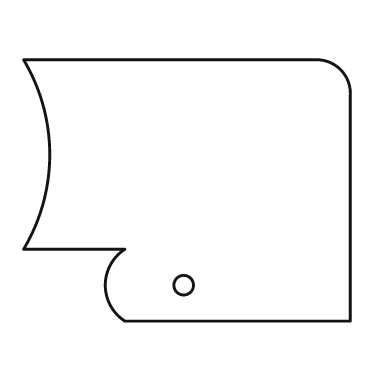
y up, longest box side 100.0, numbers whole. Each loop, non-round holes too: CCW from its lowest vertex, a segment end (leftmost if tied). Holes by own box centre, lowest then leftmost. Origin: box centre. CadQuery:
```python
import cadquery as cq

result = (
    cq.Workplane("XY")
    .moveTo(-19.0, -40.0)
    .lineTo(50.0, -40.0)
    .lineTo(50.0, 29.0)
    .threePointArc((47.0, 37.0), (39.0, 40.0))
    .lineTo(-50.0, 40.0)
    .threePointArc((-42.0, 11.0), (-50.0, -18.0))
    .lineTo(-19.0, -18.0)
    .threePointArc((-25.0, -29.0), (-19.0, -40.0))
    .close()
    .moveTo(-1.0, -29.0)
    .circle(3.0)
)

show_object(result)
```